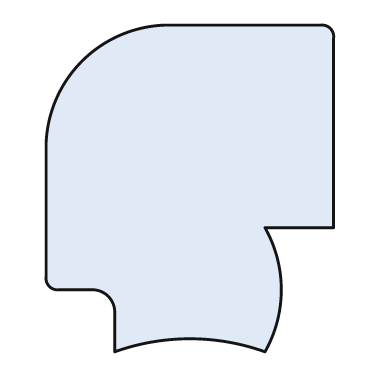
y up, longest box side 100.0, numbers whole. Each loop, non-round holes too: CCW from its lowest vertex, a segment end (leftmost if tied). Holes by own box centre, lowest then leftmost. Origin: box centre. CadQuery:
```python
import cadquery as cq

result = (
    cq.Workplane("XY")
    .moveTo(-23.0, -50.0)
    .threePointArc((0.0, -46.0), (23.0, -50.0))
    .threePointArc((28.0, -31.0), (23.0, -12.0))
    .lineTo(44.0, -12.0)
    .lineTo(44.0, 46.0)
    .threePointArc((43.0, 49.0), (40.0, 50.0))
    .lineTo(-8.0, 50.0)
    .threePointArc((-33.0, 39.0), (-44.0, 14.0))
    .lineTo(-44.0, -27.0)
    .threePointArc((-43.0, -30.0), (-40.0, -31.0))
    .lineTo(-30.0, -31.0)
    .threePointArc((-25.0, -33.0), (-23.0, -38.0))
    .close()
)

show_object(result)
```